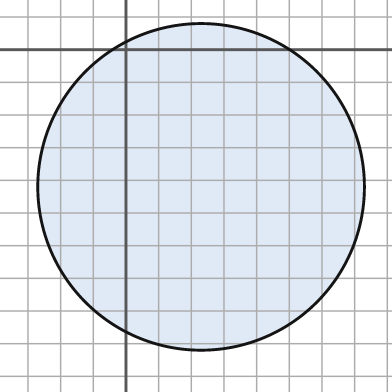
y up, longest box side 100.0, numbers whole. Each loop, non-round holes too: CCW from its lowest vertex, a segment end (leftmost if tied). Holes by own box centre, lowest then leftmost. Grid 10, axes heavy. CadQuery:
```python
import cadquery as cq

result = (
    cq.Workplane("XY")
    .moveTo(23.0, -42.0)
    .circle(50.0)
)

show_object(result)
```